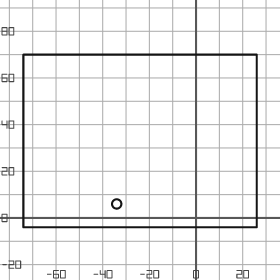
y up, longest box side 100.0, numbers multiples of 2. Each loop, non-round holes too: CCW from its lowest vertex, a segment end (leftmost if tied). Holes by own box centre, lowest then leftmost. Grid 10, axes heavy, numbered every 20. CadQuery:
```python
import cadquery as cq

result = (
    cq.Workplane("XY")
    .moveTo(-74.0, -4.0)
    .lineTo(26.0, -4.0)
    .lineTo(26.0, 70.0)
    .lineTo(-74.0, 70.0)
    .close()
    .moveTo(-34.0, 6.0)
    .circle(2.0)
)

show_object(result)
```